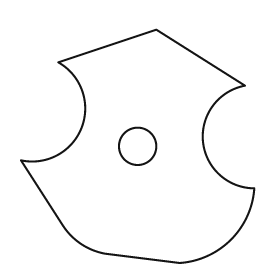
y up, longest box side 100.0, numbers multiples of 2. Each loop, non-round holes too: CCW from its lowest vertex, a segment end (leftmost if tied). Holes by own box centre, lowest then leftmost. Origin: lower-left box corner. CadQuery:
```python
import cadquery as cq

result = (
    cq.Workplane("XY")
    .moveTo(68.0, 0.0)
    .threePointArc((90.0, 10.0), (100.0, 32.0))
    .threePointArc((78.0, 52.0), (96.0, 76.0))
    .lineTo(58.0, 100.0)
    .lineTo(16.0, 86.0)
    .threePointArc((26.0, 58.0), (0.0, 44.0))
    .lineTo(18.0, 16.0)
    .threePointArc((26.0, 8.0), (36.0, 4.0))
    .close()
    .moveTo(50.0, 50.0)
    .circle(8.0)
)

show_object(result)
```